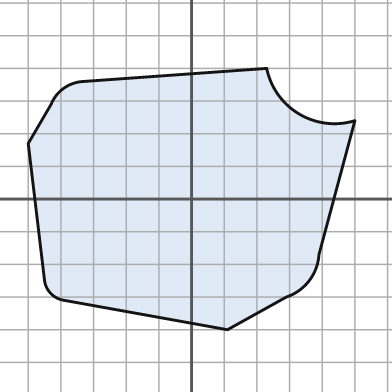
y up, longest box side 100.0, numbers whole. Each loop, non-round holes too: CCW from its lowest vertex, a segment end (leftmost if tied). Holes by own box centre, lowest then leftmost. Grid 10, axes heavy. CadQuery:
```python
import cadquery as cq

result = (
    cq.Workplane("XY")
    .moveTo(11.0, -40.0)
    .lineTo(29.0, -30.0)
    .threePointArc((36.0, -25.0), (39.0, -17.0))
    .lineTo(50.0, 24.0)
    .threePointArc((33.0, 26.0), (23.0, 40.0))
    .lineTo(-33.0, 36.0)
    .threePointArc((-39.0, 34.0), (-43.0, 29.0))
    .lineTo(-50.0, 17.0)
    .lineTo(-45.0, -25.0)
    .threePointArc((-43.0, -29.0), (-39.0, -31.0))
    .close()
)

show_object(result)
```